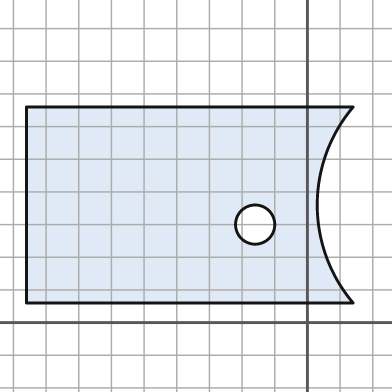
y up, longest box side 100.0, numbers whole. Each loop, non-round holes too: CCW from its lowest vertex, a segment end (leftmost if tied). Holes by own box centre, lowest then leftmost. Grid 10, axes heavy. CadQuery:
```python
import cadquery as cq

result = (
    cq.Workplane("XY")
    .moveTo(-86.0, 6.0)
    .lineTo(14.0, 6.0)
    .threePointArc((3.0, 36.0), (14.0, 66.0))
    .lineTo(-86.0, 66.0)
    .close()
    .moveTo(-16.0, 30.0)
    .circle(6.0)
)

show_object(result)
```